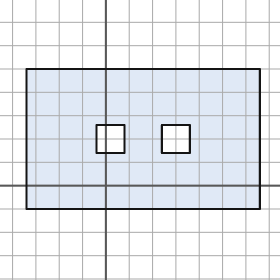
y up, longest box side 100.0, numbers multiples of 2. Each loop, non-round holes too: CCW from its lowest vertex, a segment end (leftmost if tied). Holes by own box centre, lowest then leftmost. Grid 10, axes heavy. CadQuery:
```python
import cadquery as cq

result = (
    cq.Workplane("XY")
    .moveTo(-34.0, -10.0)
    .lineTo(66.0, -10.0)
    .lineTo(66.0, 50.0)
    .lineTo(-34.0, 50.0)
    .close()
    .moveTo(-4.0, 14.0)
    .lineTo(8.0, 14.0)
    .lineTo(8.0, 26.0)
    .lineTo(-4.0, 26.0)
    .close()
    .moveTo(24.0, 14.0)
    .lineTo(36.0, 14.0)
    .lineTo(36.0, 26.0)
    .lineTo(24.0, 26.0)
    .close()
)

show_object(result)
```